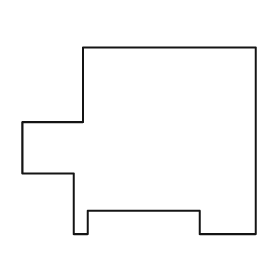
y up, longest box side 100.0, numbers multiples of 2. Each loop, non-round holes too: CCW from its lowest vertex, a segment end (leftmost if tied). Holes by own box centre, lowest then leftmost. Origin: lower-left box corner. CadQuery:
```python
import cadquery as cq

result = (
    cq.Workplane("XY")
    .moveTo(22.0, 0.0)
    .lineTo(28.0, 0.0)
    .lineTo(28.0, 10.0)
    .lineTo(76.0, 10.0)
    .lineTo(76.0, 0.0)
    .lineTo(100.0, 0.0)
    .lineTo(100.0, 80.0)
    .lineTo(26.0, 80.0)
    .lineTo(26.0, 48.0)
    .lineTo(0.0, 48.0)
    .lineTo(0.0, 26.0)
    .lineTo(22.0, 26.0)
    .close()
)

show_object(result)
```